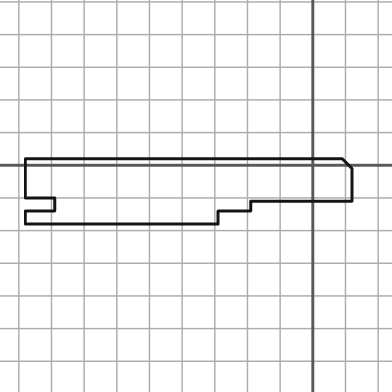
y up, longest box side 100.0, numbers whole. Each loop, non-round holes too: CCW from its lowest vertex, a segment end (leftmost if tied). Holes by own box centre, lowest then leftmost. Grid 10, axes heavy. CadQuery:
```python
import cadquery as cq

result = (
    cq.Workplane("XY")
    .moveTo(-88.0, -18.0)
    .lineTo(-29.0, -18.0)
    .lineTo(-29.0, -14.0)
    .lineTo(-19.0, -14.0)
    .lineTo(-19.0, -11.0)
    .lineTo(12.0, -11.0)
    .lineTo(12.0, -1.0)
    .lineTo(9.0, 2.0)
    .lineTo(-88.0, 2.0)
    .lineTo(-88.0, -10.0)
    .lineTo(-79.0, -10.0)
    .lineTo(-79.0, -14.0)
    .lineTo(-88.0, -14.0)
    .close()
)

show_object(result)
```